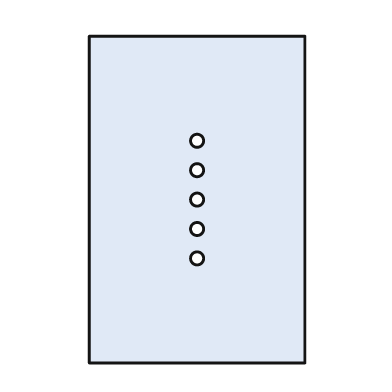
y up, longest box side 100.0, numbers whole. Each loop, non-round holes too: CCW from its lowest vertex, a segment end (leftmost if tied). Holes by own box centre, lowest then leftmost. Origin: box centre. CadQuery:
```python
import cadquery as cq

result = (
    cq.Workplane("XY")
    .moveTo(-33.0, -50.0)
    .lineTo(33.0, -50.0)
    .lineTo(33.0, 50.0)
    .lineTo(-33.0, 50.0)
    .close()
    .moveTo(0.0, -18.0)
    .circle(2.0)
    .moveTo(0.0, -9.0)
    .circle(2.0)
    .moveTo(0.0, 0.0)
    .circle(2.0)
    .moveTo(0.0, 9.0)
    .circle(2.0)
    .moveTo(0.0, 18.0)
    .circle(2.0)
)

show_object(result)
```